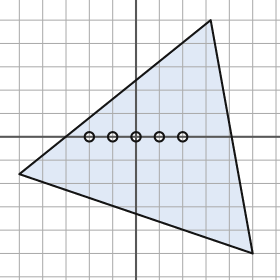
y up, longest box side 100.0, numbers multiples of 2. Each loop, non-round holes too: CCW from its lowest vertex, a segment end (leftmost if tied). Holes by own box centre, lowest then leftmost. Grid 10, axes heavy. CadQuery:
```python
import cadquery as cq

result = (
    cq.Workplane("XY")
    .moveTo(50.0, -50.0)
    .lineTo(32.0, 50.0)
    .lineTo(-50.0, -16.0)
    .close()
    .moveTo(-20.0, 0.0)
    .circle(2.0)
    .moveTo(-10.0, 0.0)
    .circle(2.0)
    .moveTo(0.0, 0.0)
    .circle(2.0)
    .moveTo(10.0, 0.0)
    .circle(2.0)
    .moveTo(20.0, 0.0)
    .circle(2.0)
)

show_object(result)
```